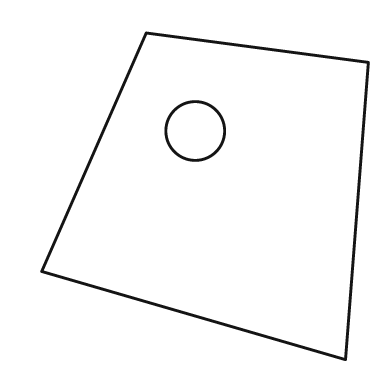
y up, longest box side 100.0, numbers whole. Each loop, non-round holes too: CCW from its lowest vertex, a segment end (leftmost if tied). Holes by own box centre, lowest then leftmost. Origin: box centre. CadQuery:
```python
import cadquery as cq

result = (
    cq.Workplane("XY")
    .moveTo(43.0, -50.0)
    .lineTo(50.0, 41.0)
    .lineTo(-18.0, 50.0)
    .lineTo(-50.0, -23.0)
    .close()
    .moveTo(-3.0, 20.0)
    .circle(9.0)
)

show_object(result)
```